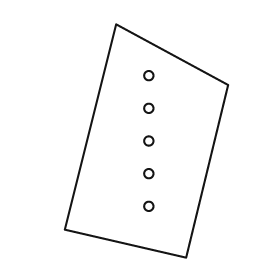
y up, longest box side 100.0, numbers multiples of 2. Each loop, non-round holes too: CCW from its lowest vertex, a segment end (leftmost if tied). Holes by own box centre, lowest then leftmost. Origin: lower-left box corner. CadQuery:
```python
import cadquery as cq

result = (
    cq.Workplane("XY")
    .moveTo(52.0, 0.0)
    .lineTo(70.0, 74.0)
    .lineTo(22.0, 100.0)
    .lineTo(0.0, 12.0)
    .close()
    .moveTo(36.0, 22.0)
    .circle(2.0)
    .moveTo(36.0, 36.0)
    .circle(2.0)
    .moveTo(36.0, 50.0)
    .circle(2.0)
    .moveTo(36.0, 64.0)
    .circle(2.0)
    .moveTo(36.0, 78.0)
    .circle(2.0)
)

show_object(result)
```